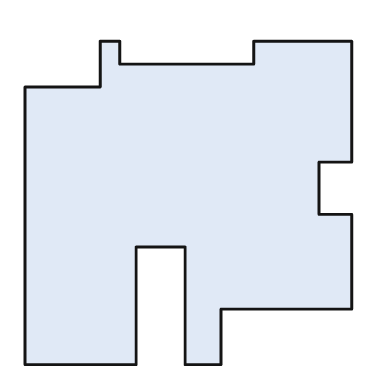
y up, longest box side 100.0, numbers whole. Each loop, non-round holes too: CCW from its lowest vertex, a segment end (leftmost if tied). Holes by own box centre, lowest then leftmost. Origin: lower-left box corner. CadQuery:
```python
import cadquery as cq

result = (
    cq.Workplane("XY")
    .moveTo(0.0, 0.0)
    .lineTo(34.0, 0.0)
    .lineTo(34.0, 36.0)
    .lineTo(49.0, 36.0)
    .lineTo(49.0, 0.0)
    .lineTo(60.0, 0.0)
    .lineTo(60.0, 17.0)
    .lineTo(100.0, 17.0)
    .lineTo(100.0, 46.0)
    .lineTo(90.0, 46.0)
    .lineTo(90.0, 62.0)
    .lineTo(100.0, 62.0)
    .lineTo(100.0, 99.0)
    .lineTo(70.0, 99.0)
    .lineTo(70.0, 92.0)
    .lineTo(29.0, 92.0)
    .lineTo(29.0, 99.0)
    .lineTo(23.0, 99.0)
    .lineTo(23.0, 85.0)
    .lineTo(0.0, 85.0)
    .close()
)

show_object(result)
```